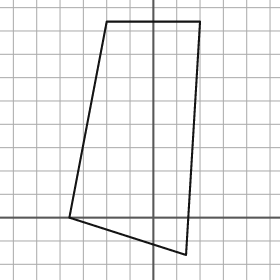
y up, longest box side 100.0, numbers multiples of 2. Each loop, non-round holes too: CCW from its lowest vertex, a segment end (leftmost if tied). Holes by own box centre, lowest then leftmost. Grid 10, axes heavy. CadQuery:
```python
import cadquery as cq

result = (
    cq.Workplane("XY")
    .moveTo(14.0, -16.0)
    .lineTo(20.0, 84.0)
    .lineTo(-20.0, 84.0)
    .lineTo(-36.0, 0.0)
    .close()
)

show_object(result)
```